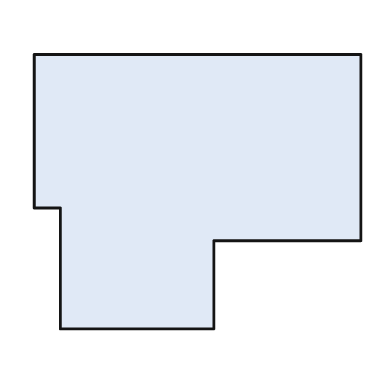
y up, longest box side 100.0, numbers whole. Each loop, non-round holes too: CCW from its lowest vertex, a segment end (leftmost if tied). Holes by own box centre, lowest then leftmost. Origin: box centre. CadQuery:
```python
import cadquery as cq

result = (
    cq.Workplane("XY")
    .moveTo(-42.0, -42.0)
    .lineTo(5.0, -42.0)
    .lineTo(5.0, -15.0)
    .lineTo(50.0, -15.0)
    .lineTo(50.0, 42.0)
    .lineTo(-50.0, 42.0)
    .lineTo(-50.0, -5.0)
    .lineTo(-42.0, -5.0)
    .close()
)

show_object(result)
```